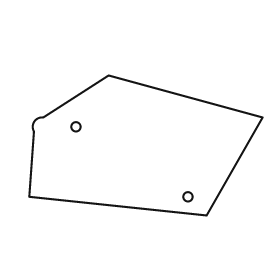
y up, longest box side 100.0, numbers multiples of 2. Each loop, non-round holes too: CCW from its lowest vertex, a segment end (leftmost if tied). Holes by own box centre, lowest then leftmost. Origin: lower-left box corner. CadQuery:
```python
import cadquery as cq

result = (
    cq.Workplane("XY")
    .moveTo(76.0, 0.0)
    .lineTo(100.0, 42.0)
    .lineTo(34.0, 60.0)
    .lineTo(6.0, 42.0)
    .threePointArc((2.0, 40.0), (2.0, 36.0))
    .lineTo(0.0, 8.0)
    .close()
    .moveTo(68.0, 8.0)
    .circle(2.0)
    .moveTo(20.0, 38.0)
    .circle(2.0)
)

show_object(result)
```